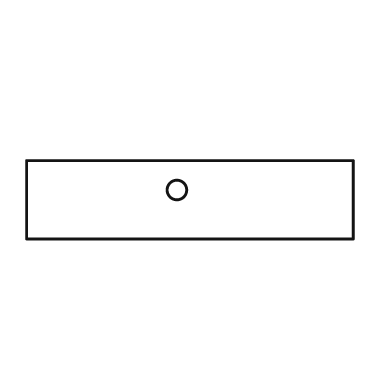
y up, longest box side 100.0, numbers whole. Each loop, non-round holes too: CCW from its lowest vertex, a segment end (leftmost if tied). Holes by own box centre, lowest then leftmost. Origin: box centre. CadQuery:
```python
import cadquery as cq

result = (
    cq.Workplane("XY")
    .moveTo(-50.0, -12.0)
    .lineTo(50.0, -12.0)
    .lineTo(50.0, 12.0)
    .lineTo(-50.0, 12.0)
    .close()
    .moveTo(-4.0, 3.0)
    .circle(3.0)
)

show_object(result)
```